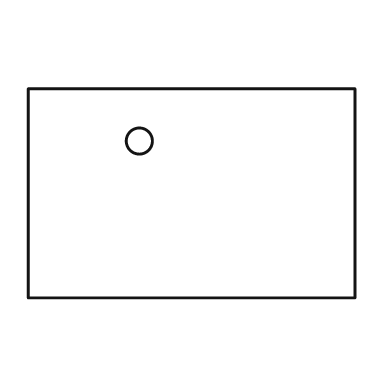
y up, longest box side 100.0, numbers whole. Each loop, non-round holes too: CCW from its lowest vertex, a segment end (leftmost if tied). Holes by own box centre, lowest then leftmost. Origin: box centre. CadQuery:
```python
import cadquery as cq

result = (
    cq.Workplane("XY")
    .moveTo(-50.0, -32.0)
    .lineTo(50.0, -32.0)
    .lineTo(50.0, 32.0)
    .lineTo(-50.0, 32.0)
    .close()
    .moveTo(-16.0, 16.0)
    .circle(4.0)
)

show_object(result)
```